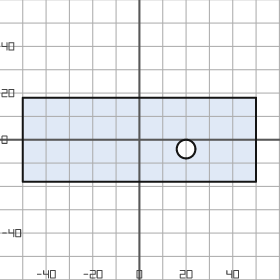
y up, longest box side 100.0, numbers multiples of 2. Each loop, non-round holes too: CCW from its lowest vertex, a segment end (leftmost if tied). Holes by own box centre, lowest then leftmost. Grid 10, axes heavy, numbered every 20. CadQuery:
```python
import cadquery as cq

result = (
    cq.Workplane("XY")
    .moveTo(-50.0, -18.0)
    .lineTo(50.0, -18.0)
    .lineTo(50.0, 18.0)
    .lineTo(-50.0, 18.0)
    .close()
    .moveTo(20.0, -4.0)
    .circle(4.0)
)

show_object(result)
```